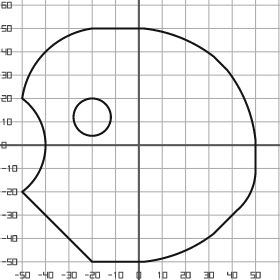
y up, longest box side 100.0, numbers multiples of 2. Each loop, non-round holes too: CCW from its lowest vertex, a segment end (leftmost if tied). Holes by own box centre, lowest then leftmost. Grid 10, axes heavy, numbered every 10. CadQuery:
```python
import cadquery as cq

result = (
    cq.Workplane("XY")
    .moveTo(-20.0, -50.0)
    .lineTo(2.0, -50.0)
    .threePointArc((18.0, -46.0), (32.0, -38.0))
    .lineTo(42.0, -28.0)
    .threePointArc((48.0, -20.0), (50.0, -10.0))
    .lineTo(50.0, 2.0)
    .threePointArc((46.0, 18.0), (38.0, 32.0))
    .lineTo(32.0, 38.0)
    .threePointArc((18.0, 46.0), (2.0, 50.0))
    .lineTo(-20.0, 50.0)
    .threePointArc((-40.0, 40.0), (-50.0, 20.0))
    .threePointArc((-40.0, 0.0), (-50.0, -20.0))
    .close()
    .moveTo(-20.0, 12.0)
    .circle(8.0)
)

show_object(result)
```